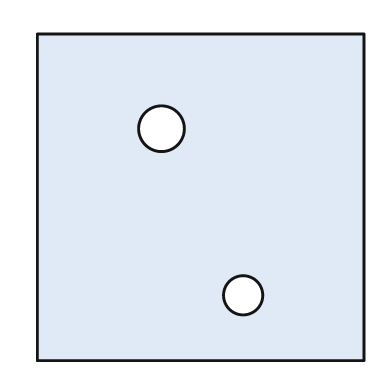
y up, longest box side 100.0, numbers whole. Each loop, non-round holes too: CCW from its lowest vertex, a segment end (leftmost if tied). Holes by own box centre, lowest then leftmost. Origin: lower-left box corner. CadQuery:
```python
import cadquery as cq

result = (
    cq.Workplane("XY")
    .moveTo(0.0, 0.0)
    .lineTo(100.0, 0.0)
    .lineTo(100.0, 100.0)
    .lineTo(0.0, 100.0)
    .close()
    .moveTo(63.0, 20.0)
    .circle(6.0)
    .moveTo(38.0, 71.0)
    .circle(7.0)
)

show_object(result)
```